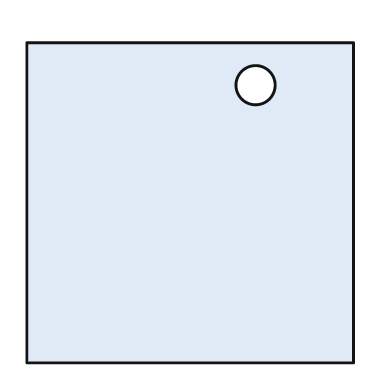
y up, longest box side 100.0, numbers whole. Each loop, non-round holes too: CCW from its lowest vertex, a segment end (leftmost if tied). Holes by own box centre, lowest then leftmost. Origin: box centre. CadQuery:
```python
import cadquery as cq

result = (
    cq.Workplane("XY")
    .moveTo(-50.0, -49.0)
    .lineTo(50.0, -49.0)
    .lineTo(50.0, 49.0)
    .lineTo(-50.0, 49.0)
    .close()
    .moveTo(20.0, 36.0)
    .circle(6.0)
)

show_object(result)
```